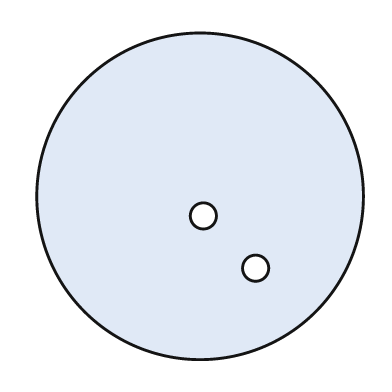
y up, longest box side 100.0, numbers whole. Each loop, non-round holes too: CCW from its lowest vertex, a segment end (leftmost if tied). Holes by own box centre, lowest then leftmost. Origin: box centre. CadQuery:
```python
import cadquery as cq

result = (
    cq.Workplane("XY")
    .moveTo(0.0, 0.0)
    .circle(50.0)
    .moveTo(17.0, -22.0)
    .circle(4.0)
    .moveTo(1.0, -6.0)
    .circle(4.0)
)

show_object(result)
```